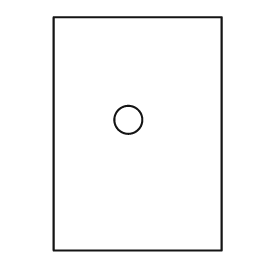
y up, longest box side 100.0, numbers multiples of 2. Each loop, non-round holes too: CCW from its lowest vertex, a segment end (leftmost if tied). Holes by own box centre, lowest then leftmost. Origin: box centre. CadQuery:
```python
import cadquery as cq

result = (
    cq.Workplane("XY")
    .moveTo(-36.0, -50.0)
    .lineTo(36.0, -50.0)
    .lineTo(36.0, 50.0)
    .lineTo(-36.0, 50.0)
    .close()
    .moveTo(-4.0, 6.0)
    .circle(6.0)
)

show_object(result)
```